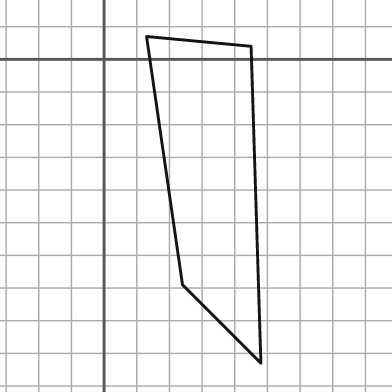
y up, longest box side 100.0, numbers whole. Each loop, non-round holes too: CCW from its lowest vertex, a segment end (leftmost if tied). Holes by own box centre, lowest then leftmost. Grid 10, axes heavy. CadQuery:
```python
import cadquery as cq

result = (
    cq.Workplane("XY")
    .moveTo(48.0, -93.0)
    .lineTo(45.0, 4.0)
    .lineTo(13.0, 7.0)
    .lineTo(24.0, -69.0)
    .close()
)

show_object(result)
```